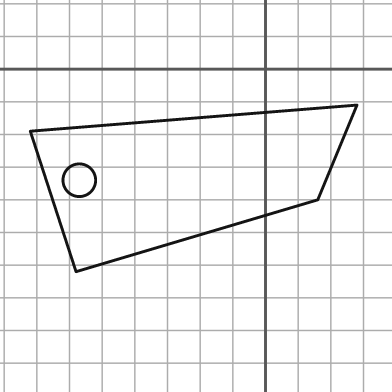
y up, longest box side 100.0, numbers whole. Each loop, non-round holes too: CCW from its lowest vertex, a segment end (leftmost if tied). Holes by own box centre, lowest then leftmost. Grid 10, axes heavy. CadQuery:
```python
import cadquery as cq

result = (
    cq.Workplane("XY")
    .moveTo(-58.0, -62.0)
    .lineTo(16.0, -40.0)
    .lineTo(28.0, -11.0)
    .lineTo(-72.0, -19.0)
    .close()
    .moveTo(-57.0, -34.0)
    .circle(5.0)
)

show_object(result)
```